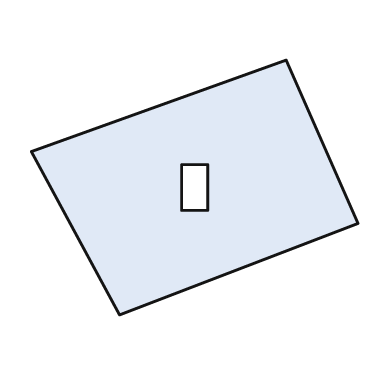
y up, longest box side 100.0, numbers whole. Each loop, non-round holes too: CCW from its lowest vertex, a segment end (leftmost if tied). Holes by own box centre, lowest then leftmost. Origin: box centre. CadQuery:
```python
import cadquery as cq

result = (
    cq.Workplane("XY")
    .moveTo(-23.0, -39.0)
    .lineTo(50.0, -11.0)
    .lineTo(28.0, 39.0)
    .lineTo(-50.0, 11.0)
    .close()
    .moveTo(-4.0, -7.0)
    .lineTo(4.0, -7.0)
    .lineTo(4.0, 7.0)
    .lineTo(-4.0, 7.0)
    .close()
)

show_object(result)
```